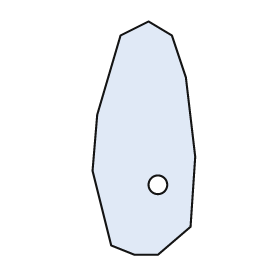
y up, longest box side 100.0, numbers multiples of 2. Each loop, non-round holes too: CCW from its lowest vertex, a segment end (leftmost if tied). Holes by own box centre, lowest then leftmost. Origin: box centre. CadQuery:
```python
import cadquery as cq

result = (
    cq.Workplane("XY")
    .moveTo(-4.0, -50.0)
    .lineTo(6.0, -50.0)
    .lineTo(20.0, -38.0)
    .lineTo(22.0, -8.0)
    .lineTo(18.0, 26.0)
    .lineTo(12.0, 44.0)
    .lineTo(2.0, 50.0)
    .lineTo(-10.0, 44.0)
    .lineTo(-20.0, 10.0)
    .lineTo(-22.0, -14.0)
    .lineTo(-14.0, -46.0)
    .close()
    .moveTo(6.0, -20.0)
    .circle(4.0)
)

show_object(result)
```